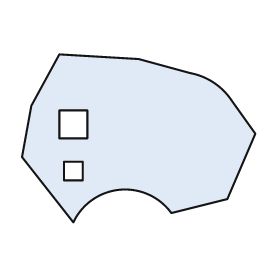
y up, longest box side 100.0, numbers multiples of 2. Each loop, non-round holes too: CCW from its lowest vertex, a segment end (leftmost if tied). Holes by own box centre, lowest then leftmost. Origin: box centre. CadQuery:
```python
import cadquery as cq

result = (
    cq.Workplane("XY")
    .moveTo(-28.0, -36.0)
    .threePointArc((-8.0, -22.0), (14.0, -32.0))
    .lineTo(38.0, -26.0)
    .lineTo(50.0, 2.0)
    .lineTo(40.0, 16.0)
    .threePointArc((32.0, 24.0), (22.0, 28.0))
    .lineTo(0.0, 34.0)
    .lineTo(-34.0, 36.0)
    .lineTo(-46.0, 14.0)
    .lineTo(-50.0, -8.0)
    .close()
    .moveTo(-32.0, -18.0)
    .lineTo(-24.0, -18.0)
    .lineTo(-24.0, -10.0)
    .lineTo(-32.0, -10.0)
    .close()
    .moveTo(-34.0, 0.0)
    .lineTo(-22.0, 0.0)
    .lineTo(-22.0, 12.0)
    .lineTo(-34.0, 12.0)
    .close()
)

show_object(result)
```